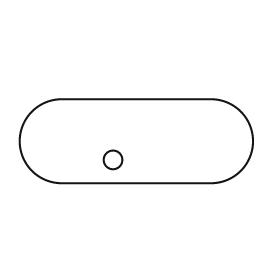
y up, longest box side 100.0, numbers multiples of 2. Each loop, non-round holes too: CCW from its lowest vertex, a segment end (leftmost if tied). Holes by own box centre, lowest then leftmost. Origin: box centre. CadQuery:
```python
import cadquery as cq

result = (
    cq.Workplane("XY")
    .moveTo(-32.0, -18.0)
    .lineTo(32.0, -18.0)
    .threePointArc((50.0, 0.0), (32.0, 18.0))
    .lineTo(-32.0, 18.0)
    .threePointArc((-50.0, 0.0), (-32.0, -18.0))
    .close()
    .moveTo(-10.0, -8.0)
    .circle(4.0)
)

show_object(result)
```